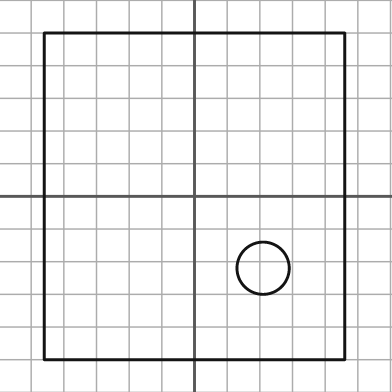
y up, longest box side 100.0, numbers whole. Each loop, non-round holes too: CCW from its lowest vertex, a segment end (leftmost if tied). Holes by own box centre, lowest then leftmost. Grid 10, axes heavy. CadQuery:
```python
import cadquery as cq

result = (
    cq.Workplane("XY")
    .moveTo(-46.0, -50.0)
    .lineTo(46.0, -50.0)
    .lineTo(46.0, 50.0)
    .lineTo(-46.0, 50.0)
    .close()
    .moveTo(21.0, -22.0)
    .circle(8.0)
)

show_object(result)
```